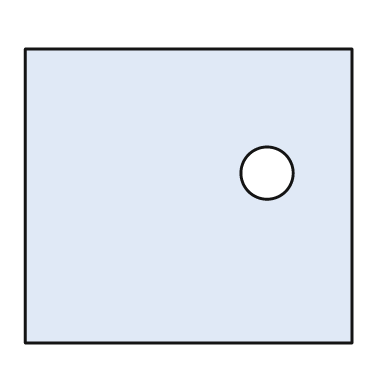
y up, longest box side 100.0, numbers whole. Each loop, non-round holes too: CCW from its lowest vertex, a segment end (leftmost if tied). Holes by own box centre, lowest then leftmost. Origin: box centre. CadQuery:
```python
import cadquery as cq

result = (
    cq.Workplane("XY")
    .moveTo(-50.0, -45.0)
    .lineTo(50.0, -45.0)
    .lineTo(50.0, 45.0)
    .lineTo(-50.0, 45.0)
    .close()
    .moveTo(24.0, 7.0)
    .circle(8.0)
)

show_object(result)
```